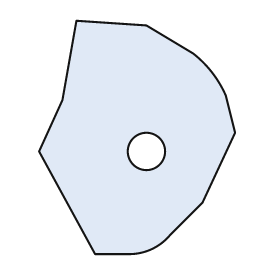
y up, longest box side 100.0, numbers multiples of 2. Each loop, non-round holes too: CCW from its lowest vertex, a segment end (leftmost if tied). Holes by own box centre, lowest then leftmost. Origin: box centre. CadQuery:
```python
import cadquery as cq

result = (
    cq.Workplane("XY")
    .moveTo(-18.0, -50.0)
    .lineTo(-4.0, -50.0)
    .threePointArc((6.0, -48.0), (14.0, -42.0))
    .lineTo(28.0, -28.0)
    .lineTo(42.0, 2.0)
    .lineTo(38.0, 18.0)
    .threePointArc((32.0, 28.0), (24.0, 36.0))
    .lineTo(4.0, 48.0)
    .lineTo(-26.0, 50.0)
    .lineTo(-32.0, 16.0)
    .lineTo(-42.0, -6.0)
    .close()
    .moveTo(4.0, -6.0)
    .circle(8.0)
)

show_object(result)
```